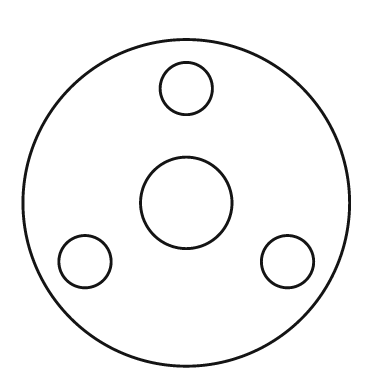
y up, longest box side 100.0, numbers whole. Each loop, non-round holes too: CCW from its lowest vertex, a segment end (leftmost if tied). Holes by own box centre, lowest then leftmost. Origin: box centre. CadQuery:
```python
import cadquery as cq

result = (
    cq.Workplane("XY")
    .moveTo(0.0, 0.0)
    .circle(50.0)
    .moveTo(-31.0, -18.0)
    .circle(8.0)
    .moveTo(31.0, -18.0)
    .circle(8.0)
    .moveTo(0.0, 0.0)
    .circle(14.0)
    .moveTo(0.0, 35.0)
    .circle(8.0)
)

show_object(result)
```